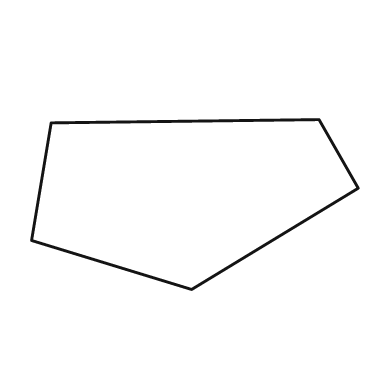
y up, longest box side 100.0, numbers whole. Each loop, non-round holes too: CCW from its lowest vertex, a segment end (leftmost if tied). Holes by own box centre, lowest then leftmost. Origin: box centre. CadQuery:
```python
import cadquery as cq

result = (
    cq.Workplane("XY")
    .moveTo(-1.0, -26.0)
    .lineTo(50.0, 5.0)
    .lineTo(38.0, 26.0)
    .lineTo(-44.0, 25.0)
    .lineTo(-50.0, -11.0)
    .close()
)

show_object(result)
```